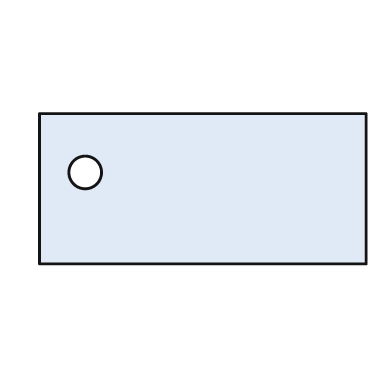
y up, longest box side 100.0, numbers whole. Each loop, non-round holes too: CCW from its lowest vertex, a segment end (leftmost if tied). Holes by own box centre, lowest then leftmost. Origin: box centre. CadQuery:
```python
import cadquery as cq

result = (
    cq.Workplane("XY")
    .moveTo(-50.0, -23.0)
    .lineTo(50.0, -23.0)
    .lineTo(50.0, 23.0)
    .lineTo(-50.0, 23.0)
    .close()
    .moveTo(-36.0, 5.0)
    .circle(5.0)
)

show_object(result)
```